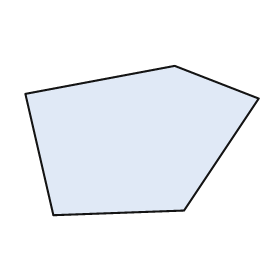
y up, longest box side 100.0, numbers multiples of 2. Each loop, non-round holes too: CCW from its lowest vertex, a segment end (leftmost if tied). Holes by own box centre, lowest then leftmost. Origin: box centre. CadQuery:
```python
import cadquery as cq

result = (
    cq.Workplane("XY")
    .moveTo(-38.0, -32.0)
    .lineTo(18.0, -30.0)
    .lineTo(50.0, 18.0)
    .lineTo(14.0, 32.0)
    .lineTo(-50.0, 20.0)
    .close()
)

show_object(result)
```